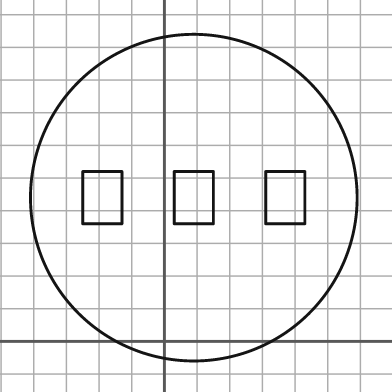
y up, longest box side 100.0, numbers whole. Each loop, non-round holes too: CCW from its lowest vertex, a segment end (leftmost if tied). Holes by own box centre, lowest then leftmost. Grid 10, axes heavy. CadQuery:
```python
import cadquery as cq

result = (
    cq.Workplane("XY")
    .moveTo(9.0, 44.0)
    .circle(50.0)
    .moveTo(-25.0, 36.0)
    .lineTo(-13.0, 36.0)
    .lineTo(-13.0, 52.0)
    .lineTo(-25.0, 52.0)
    .close()
    .moveTo(3.0, 36.0)
    .lineTo(15.0, 36.0)
    .lineTo(15.0, 52.0)
    .lineTo(3.0, 52.0)
    .close()
    .moveTo(31.0, 36.0)
    .lineTo(43.0, 36.0)
    .lineTo(43.0, 52.0)
    .lineTo(31.0, 52.0)
    .close()
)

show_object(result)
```